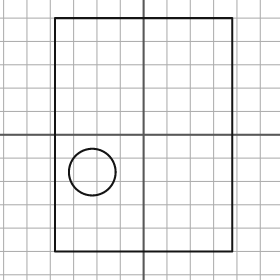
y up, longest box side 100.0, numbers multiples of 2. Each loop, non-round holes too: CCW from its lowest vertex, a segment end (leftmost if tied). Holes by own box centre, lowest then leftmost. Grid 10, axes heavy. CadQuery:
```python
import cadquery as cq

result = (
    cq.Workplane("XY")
    .moveTo(-38.0, -50.0)
    .lineTo(38.0, -50.0)
    .lineTo(38.0, 50.0)
    .lineTo(-38.0, 50.0)
    .close()
    .moveTo(-22.0, -16.0)
    .circle(10.0)
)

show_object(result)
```